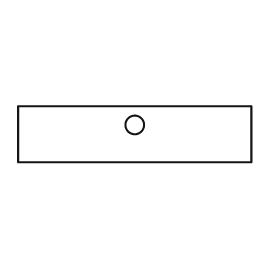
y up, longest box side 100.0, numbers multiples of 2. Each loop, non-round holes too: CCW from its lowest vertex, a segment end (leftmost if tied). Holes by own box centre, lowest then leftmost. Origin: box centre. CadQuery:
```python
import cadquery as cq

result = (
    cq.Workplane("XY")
    .moveTo(-50.0, -12.0)
    .lineTo(50.0, -12.0)
    .lineTo(50.0, 12.0)
    .lineTo(-50.0, 12.0)
    .close()
    .moveTo(0.0, 4.0)
    .circle(4.0)
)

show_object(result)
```